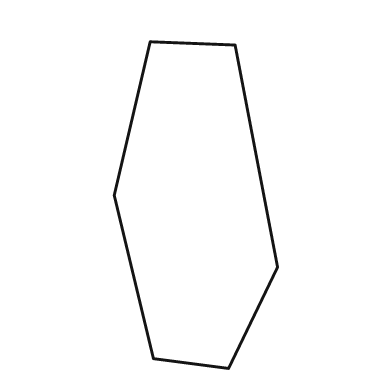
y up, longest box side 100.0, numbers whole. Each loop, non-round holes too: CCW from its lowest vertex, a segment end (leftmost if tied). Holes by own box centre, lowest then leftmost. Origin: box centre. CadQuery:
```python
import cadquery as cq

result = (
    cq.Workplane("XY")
    .moveTo(10.0, -50.0)
    .lineTo(25.0, -19.0)
    .lineTo(12.0, 49.0)
    .lineTo(-14.0, 50.0)
    .lineTo(-25.0, 3.0)
    .lineTo(-13.0, -47.0)
    .close()
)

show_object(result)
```